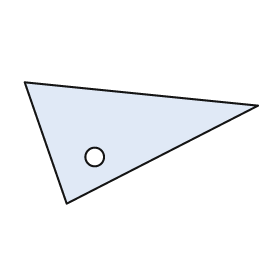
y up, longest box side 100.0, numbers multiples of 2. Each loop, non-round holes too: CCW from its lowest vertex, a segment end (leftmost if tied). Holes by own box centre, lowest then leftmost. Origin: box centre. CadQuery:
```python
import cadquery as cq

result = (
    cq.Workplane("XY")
    .moveTo(-32.0, -26.0)
    .lineTo(50.0, 16.0)
    .lineTo(-50.0, 26.0)
    .close()
    .moveTo(-20.0, -6.0)
    .circle(4.0)
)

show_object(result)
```